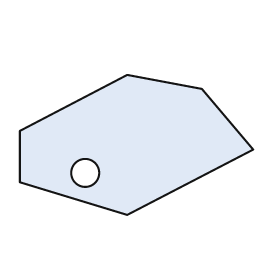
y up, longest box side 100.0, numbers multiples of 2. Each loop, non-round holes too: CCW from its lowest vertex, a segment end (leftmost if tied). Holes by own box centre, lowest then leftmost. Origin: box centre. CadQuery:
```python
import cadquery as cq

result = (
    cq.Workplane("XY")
    .moveTo(-4.0, -30.0)
    .lineTo(50.0, -2.0)
    .lineTo(28.0, 24.0)
    .lineTo(-4.0, 30.0)
    .lineTo(-50.0, 6.0)
    .lineTo(-50.0, -16.0)
    .close()
    .moveTo(-22.0, -12.0)
    .circle(6.0)
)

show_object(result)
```